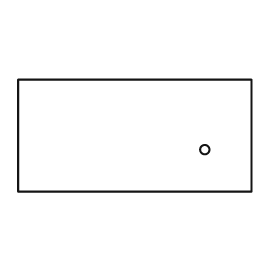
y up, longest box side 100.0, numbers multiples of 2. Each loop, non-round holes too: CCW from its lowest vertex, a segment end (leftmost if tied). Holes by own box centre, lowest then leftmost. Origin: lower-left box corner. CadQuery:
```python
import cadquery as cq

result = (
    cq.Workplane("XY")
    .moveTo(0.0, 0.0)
    .lineTo(100.0, 0.0)
    .lineTo(100.0, 48.0)
    .lineTo(0.0, 48.0)
    .close()
    .moveTo(80.0, 18.0)
    .circle(2.0)
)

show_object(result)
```